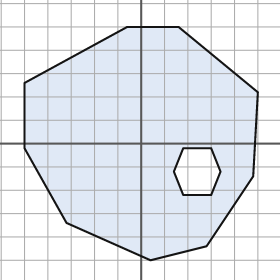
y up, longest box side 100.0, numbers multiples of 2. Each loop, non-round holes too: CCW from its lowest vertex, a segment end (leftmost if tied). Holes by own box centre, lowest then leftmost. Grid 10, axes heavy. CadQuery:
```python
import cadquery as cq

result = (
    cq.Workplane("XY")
    .moveTo(4.0, -50.0)
    .lineTo(28.0, -44.0)
    .lineTo(48.0, -14.0)
    .lineTo(50.0, 22.0)
    .lineTo(16.0, 50.0)
    .lineTo(-6.0, 50.0)
    .lineTo(-50.0, 26.0)
    .lineTo(-50.0, -2.0)
    .lineTo(-32.0, -34.0)
    .close()
    .moveTo(18.0, -22.0)
    .lineTo(30.0, -22.0)
    .lineTo(34.0, -12.0)
    .lineTo(30.0, -2.0)
    .lineTo(18.0, -2.0)
    .lineTo(14.0, -12.0)
    .close()
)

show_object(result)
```